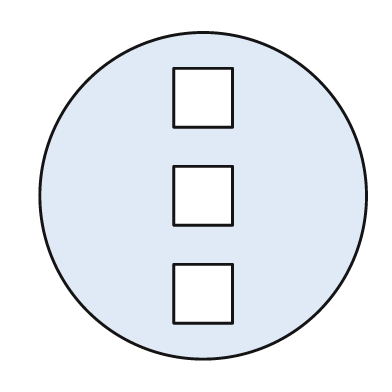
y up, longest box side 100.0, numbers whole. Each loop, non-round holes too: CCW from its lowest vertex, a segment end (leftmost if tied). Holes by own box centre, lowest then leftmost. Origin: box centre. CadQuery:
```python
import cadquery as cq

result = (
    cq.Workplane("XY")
    .moveTo(0.0, 0.0)
    .circle(50.0)
    .moveTo(-9.0, -39.0)
    .lineTo(9.0, -39.0)
    .lineTo(9.0, -21.0)
    .lineTo(-9.0, -21.0)
    .close()
    .moveTo(-9.0, -9.0)
    .lineTo(9.0, -9.0)
    .lineTo(9.0, 9.0)
    .lineTo(-9.0, 9.0)
    .close()
    .moveTo(-9.0, 21.0)
    .lineTo(9.0, 21.0)
    .lineTo(9.0, 39.0)
    .lineTo(-9.0, 39.0)
    .close()
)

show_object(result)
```